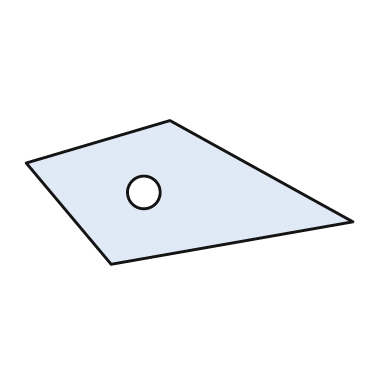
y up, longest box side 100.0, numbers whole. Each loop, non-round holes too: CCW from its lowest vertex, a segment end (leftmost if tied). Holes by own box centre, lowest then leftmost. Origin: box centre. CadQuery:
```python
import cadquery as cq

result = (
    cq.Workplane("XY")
    .moveTo(-24.0, -22.0)
    .lineTo(50.0, -9.0)
    .lineTo(-6.0, 22.0)
    .lineTo(-50.0, 9.0)
    .close()
    .moveTo(-14.0, 0.0)
    .circle(5.0)
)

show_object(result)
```